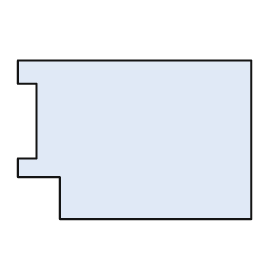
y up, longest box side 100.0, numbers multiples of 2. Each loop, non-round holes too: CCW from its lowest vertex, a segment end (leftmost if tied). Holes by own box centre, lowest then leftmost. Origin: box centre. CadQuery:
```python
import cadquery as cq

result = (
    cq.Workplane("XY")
    .moveTo(-32.0, -34.0)
    .lineTo(50.0, -34.0)
    .lineTo(50.0, 34.0)
    .lineTo(-50.0, 34.0)
    .lineTo(-50.0, 24.0)
    .lineTo(-42.0, 24.0)
    .lineTo(-42.0, -8.0)
    .lineTo(-50.0, -8.0)
    .lineTo(-50.0, -16.0)
    .lineTo(-32.0, -16.0)
    .close()
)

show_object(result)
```